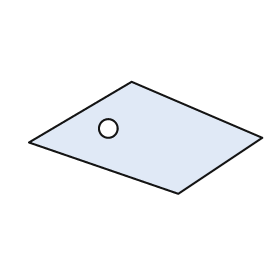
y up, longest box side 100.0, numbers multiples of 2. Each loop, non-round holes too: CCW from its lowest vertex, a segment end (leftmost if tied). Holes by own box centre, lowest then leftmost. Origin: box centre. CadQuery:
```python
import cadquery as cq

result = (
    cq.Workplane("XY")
    .moveTo(14.0, -24.0)
    .lineTo(50.0, 0.0)
    .lineTo(-6.0, 24.0)
    .lineTo(-50.0, -2.0)
    .close()
    .moveTo(-16.0, 4.0)
    .circle(4.0)
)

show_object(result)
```